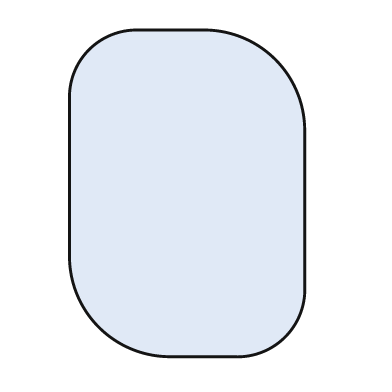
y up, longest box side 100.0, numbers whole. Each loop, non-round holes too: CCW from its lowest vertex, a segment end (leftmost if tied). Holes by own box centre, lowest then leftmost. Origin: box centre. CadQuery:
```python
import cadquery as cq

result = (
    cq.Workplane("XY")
    .moveTo(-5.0, -50.0)
    .lineTo(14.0, -50.0)
    .threePointArc((30.0, -44.0), (36.0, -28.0))
    .lineTo(36.0, 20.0)
    .threePointArc((27.0, 41.0), (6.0, 50.0))
    .lineTo(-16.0, 50.0)
    .threePointArc((-30.0, 44.0), (-36.0, 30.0))
    .lineTo(-36.0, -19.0)
    .threePointArc((-27.0, -41.0), (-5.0, -50.0))
    .close()
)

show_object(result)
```